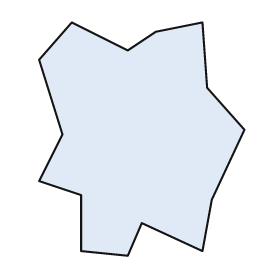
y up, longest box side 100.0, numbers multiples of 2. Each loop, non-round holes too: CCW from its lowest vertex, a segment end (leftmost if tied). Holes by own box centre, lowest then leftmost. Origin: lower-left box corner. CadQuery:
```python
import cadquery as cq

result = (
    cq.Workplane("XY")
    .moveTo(38.0, 0.0)
    .lineTo(44.0, 14.0)
    .lineTo(70.0, 2.0)
    .lineTo(74.0, 24.0)
    .lineTo(88.0, 54.0)
    .lineTo(72.0, 72.0)
    .lineTo(70.0, 100.0)
    .lineTo(50.0, 96.0)
    .lineTo(38.0, 88.0)
    .lineTo(14.0, 100.0)
    .lineTo(0.0, 84.0)
    .lineTo(10.0, 52.0)
    .lineTo(0.0, 32.0)
    .lineTo(18.0, 26.0)
    .lineTo(18.0, 2.0)
    .close()
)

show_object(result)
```